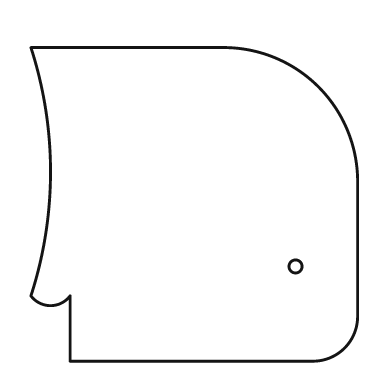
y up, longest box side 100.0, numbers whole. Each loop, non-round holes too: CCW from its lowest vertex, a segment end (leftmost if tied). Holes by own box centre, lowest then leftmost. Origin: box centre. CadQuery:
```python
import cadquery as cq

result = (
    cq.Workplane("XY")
    .moveTo(-38.0, -48.0)
    .lineTo(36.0, -48.0)
    .threePointArc((46.0, -44.0), (50.0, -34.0))
    .lineTo(50.0, 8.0)
    .threePointArc((38.0, 36.0), (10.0, 48.0))
    .lineTo(-50.0, 48.0)
    .threePointArc((-44.0, 10.0), (-50.0, -28.0))
    .threePointArc((-44.0, -31.0), (-38.0, -28.0))
    .close()
    .moveTo(31.0, -19.0)
    .circle(2.0)
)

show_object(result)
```